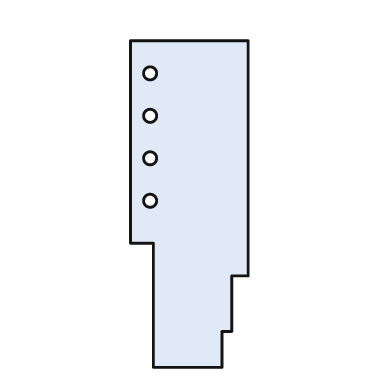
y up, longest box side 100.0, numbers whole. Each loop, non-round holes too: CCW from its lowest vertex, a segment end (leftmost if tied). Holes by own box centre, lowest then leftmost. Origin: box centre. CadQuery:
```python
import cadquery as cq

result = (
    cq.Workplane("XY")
    .moveTo(-11.0, -50.0)
    .lineTo(10.0, -50.0)
    .lineTo(10.0, -39.0)
    .lineTo(13.0, -39.0)
    .lineTo(13.0, -22.0)
    .lineTo(18.0, -22.0)
    .lineTo(18.0, 50.0)
    .lineTo(-18.0, 50.0)
    .lineTo(-18.0, -12.0)
    .lineTo(-11.0, -12.0)
    .close()
    .moveTo(-12.0, 1.0)
    .circle(2.0)
    .moveTo(-12.0, 14.0)
    .circle(2.0)
    .moveTo(-12.0, 27.0)
    .circle(2.0)
    .moveTo(-12.0, 40.0)
    .circle(2.0)
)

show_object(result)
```